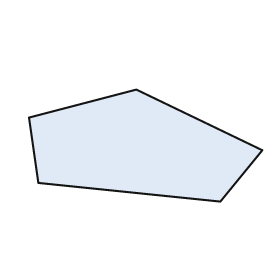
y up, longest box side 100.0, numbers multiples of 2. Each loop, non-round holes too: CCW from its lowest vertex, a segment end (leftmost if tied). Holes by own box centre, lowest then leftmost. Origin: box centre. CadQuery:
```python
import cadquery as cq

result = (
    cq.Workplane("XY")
    .moveTo(32.0, -24.0)
    .lineTo(50.0, -2.0)
    .lineTo(-4.0, 24.0)
    .lineTo(-50.0, 12.0)
    .lineTo(-46.0, -16.0)
    .close()
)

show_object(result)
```